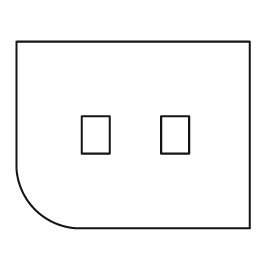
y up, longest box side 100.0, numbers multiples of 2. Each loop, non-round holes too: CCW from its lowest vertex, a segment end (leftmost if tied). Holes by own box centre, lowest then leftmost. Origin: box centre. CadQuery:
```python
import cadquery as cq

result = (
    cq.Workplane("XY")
    .moveTo(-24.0, -40.0)
    .lineTo(50.0, -40.0)
    .lineTo(50.0, 40.0)
    .lineTo(-50.0, 40.0)
    .lineTo(-50.0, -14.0)
    .threePointArc((-42.0, -32.0), (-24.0, -40.0))
    .close()
    .moveTo(-22.0, -8.0)
    .lineTo(-10.0, -8.0)
    .lineTo(-10.0, 8.0)
    .lineTo(-22.0, 8.0)
    .close()
    .moveTo(12.0, -8.0)
    .lineTo(24.0, -8.0)
    .lineTo(24.0, 8.0)
    .lineTo(12.0, 8.0)
    .close()
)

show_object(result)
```